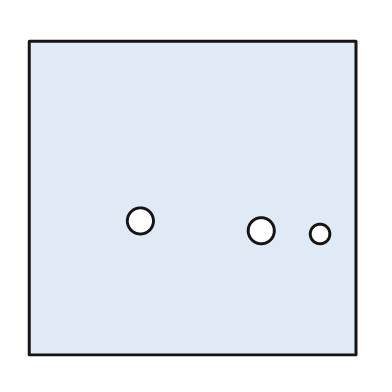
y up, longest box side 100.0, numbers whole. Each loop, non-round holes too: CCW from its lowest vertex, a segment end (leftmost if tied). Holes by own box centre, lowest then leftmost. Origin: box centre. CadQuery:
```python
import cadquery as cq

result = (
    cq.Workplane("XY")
    .moveTo(-50.0, -48.0)
    .lineTo(50.0, -48.0)
    .lineTo(50.0, 48.0)
    .lineTo(-50.0, 48.0)
    .close()
    .moveTo(39.0, -11.0)
    .circle(3.0)
    .moveTo(21.0, -10.0)
    .circle(4.0)
    .moveTo(-16.0, -7.0)
    .circle(4.0)
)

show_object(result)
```